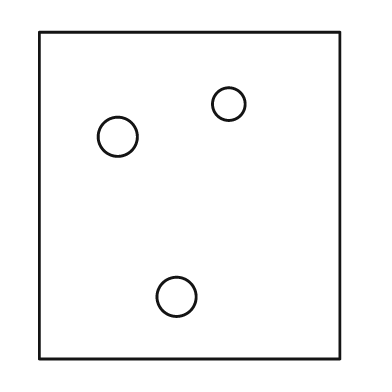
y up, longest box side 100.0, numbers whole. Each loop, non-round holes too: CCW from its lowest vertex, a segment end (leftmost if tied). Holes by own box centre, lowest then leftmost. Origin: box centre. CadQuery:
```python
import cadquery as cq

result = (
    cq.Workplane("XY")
    .moveTo(-46.0, -50.0)
    .lineTo(46.0, -50.0)
    .lineTo(46.0, 50.0)
    .lineTo(-46.0, 50.0)
    .close()
    .moveTo(-4.0, -31.0)
    .circle(6.0)
    .moveTo(-22.0, 18.0)
    .circle(6.0)
    .moveTo(12.0, 28.0)
    .circle(5.0)
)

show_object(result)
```